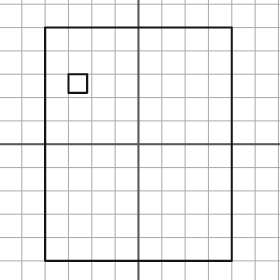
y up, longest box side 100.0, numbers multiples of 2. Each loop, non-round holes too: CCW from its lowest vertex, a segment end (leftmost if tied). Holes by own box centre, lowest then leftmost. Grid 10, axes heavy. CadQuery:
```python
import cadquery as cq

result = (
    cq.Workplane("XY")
    .moveTo(-40.0, -50.0)
    .lineTo(40.0, -50.0)
    .lineTo(40.0, 50.0)
    .lineTo(-40.0, 50.0)
    .close()
    .moveTo(-30.0, 22.0)
    .lineTo(-22.0, 22.0)
    .lineTo(-22.0, 30.0)
    .lineTo(-30.0, 30.0)
    .close()
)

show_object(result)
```